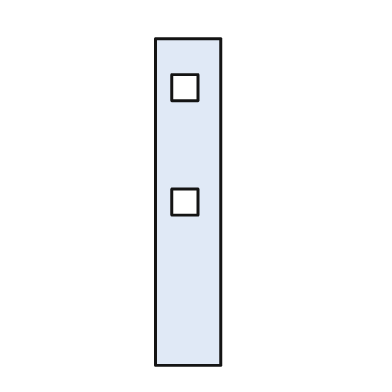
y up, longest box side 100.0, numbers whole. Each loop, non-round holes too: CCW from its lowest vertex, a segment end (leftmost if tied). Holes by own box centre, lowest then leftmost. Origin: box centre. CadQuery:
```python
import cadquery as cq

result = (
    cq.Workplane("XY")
    .moveTo(-10.0, -50.0)
    .lineTo(10.0, -50.0)
    .lineTo(10.0, 50.0)
    .lineTo(-10.0, 50.0)
    .close()
    .moveTo(-5.0, -4.0)
    .lineTo(3.0, -4.0)
    .lineTo(3.0, 4.0)
    .lineTo(-5.0, 4.0)
    .close()
    .moveTo(-5.0, 31.0)
    .lineTo(3.0, 31.0)
    .lineTo(3.0, 39.0)
    .lineTo(-5.0, 39.0)
    .close()
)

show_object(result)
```